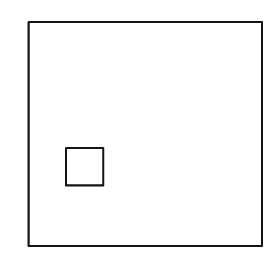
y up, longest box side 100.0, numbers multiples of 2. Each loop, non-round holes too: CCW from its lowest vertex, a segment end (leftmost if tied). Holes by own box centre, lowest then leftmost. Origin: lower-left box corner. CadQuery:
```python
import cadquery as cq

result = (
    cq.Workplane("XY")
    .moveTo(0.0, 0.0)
    .lineTo(100.0, 0.0)
    .lineTo(100.0, 96.0)
    .lineTo(0.0, 96.0)
    .close()
    .moveTo(16.0, 26.0)
    .lineTo(32.0, 26.0)
    .lineTo(32.0, 42.0)
    .lineTo(16.0, 42.0)
    .close()
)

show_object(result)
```